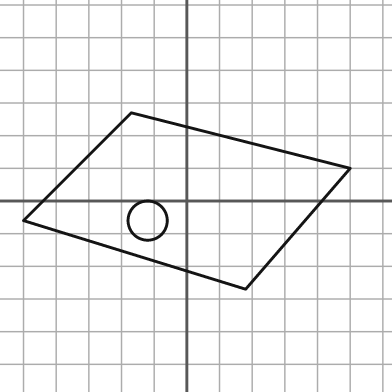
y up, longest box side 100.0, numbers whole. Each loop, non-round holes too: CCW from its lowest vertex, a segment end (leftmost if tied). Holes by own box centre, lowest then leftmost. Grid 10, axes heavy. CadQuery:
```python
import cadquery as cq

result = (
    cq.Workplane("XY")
    .moveTo(18.0, -27.0)
    .lineTo(50.0, 10.0)
    .lineTo(-17.0, 27.0)
    .lineTo(-50.0, -6.0)
    .close()
    .moveTo(-12.0, -6.0)
    .circle(6.0)
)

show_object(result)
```